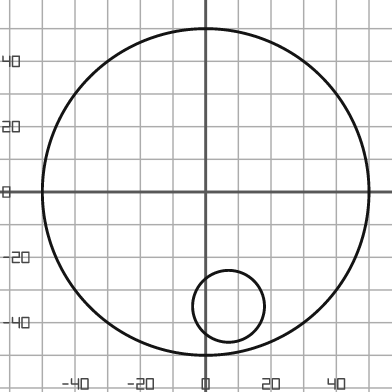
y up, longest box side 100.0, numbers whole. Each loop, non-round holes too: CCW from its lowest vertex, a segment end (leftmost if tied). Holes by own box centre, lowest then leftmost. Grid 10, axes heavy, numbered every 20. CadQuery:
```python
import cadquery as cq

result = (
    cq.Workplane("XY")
    .moveTo(0.0, 0.0)
    .circle(50.0)
    .moveTo(7.0, -35.0)
    .circle(11.0)
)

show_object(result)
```